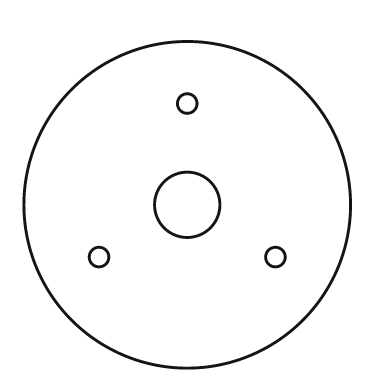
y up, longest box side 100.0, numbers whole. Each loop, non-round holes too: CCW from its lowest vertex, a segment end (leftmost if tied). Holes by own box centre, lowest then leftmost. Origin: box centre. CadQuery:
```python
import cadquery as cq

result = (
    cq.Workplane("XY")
    .moveTo(0.0, 0.0)
    .circle(50.0)
    .moveTo(-27.0, -16.0)
    .circle(3.0)
    .moveTo(27.0, -16.0)
    .circle(3.0)
    .moveTo(0.0, 0.0)
    .circle(10.0)
    .moveTo(0.0, 31.0)
    .circle(3.0)
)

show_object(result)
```